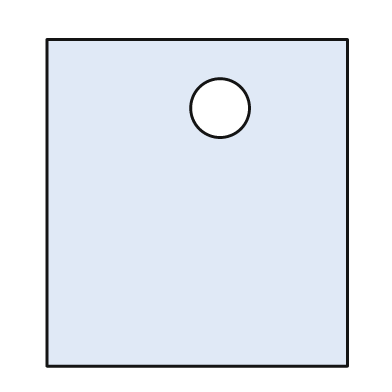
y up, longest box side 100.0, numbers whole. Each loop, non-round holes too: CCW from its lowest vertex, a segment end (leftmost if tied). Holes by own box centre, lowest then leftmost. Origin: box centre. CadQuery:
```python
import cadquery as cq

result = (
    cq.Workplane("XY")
    .moveTo(-46.0, -50.0)
    .lineTo(46.0, -50.0)
    .lineTo(46.0, 50.0)
    .lineTo(-46.0, 50.0)
    .close()
    .moveTo(7.0, 29.0)
    .circle(9.0)
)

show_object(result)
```